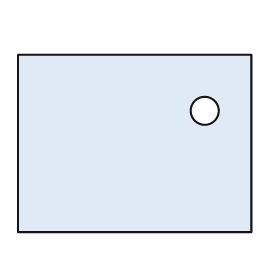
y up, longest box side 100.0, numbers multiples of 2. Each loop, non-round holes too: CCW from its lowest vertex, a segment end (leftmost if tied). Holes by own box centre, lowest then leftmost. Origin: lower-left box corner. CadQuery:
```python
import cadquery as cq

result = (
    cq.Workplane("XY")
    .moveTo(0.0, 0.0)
    .lineTo(100.0, 0.0)
    .lineTo(100.0, 76.0)
    .lineTo(0.0, 76.0)
    .close()
    .moveTo(80.0, 52.0)
    .circle(6.0)
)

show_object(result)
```